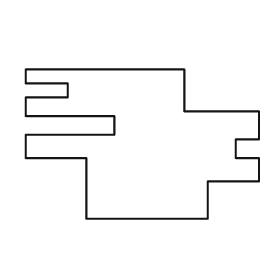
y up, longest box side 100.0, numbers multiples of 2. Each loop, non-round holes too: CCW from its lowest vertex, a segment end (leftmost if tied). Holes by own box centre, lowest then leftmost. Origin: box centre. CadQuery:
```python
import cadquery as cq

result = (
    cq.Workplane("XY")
    .moveTo(-24.0, -32.0)
    .lineTo(28.0, -32.0)
    .lineTo(28.0, -16.0)
    .lineTo(50.0, -16.0)
    .lineTo(50.0, -6.0)
    .lineTo(40.0, -6.0)
    .lineTo(40.0, 2.0)
    .lineTo(50.0, 2.0)
    .lineTo(50.0, 14.0)
    .lineTo(18.0, 14.0)
    .lineTo(18.0, 32.0)
    .lineTo(-50.0, 32.0)
    .lineTo(-50.0, 26.0)
    .lineTo(-32.0, 26.0)
    .lineTo(-32.0, 20.0)
    .lineTo(-50.0, 20.0)
    .lineTo(-50.0, 12.0)
    .lineTo(-12.0, 12.0)
    .lineTo(-12.0, 4.0)
    .lineTo(-50.0, 4.0)
    .lineTo(-50.0, -6.0)
    .lineTo(-24.0, -6.0)
    .close()
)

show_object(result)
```